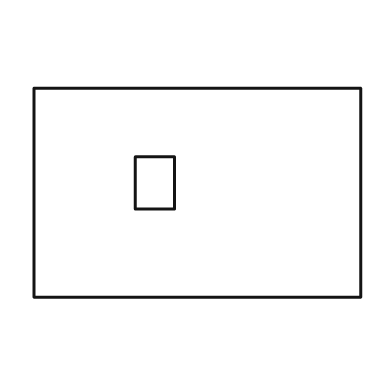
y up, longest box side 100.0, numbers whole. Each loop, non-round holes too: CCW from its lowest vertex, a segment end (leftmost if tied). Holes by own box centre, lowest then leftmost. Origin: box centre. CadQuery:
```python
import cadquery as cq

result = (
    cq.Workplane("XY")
    .moveTo(-50.0, -32.0)
    .lineTo(50.0, -32.0)
    .lineTo(50.0, 32.0)
    .lineTo(-50.0, 32.0)
    .close()
    .moveTo(-19.0, -5.0)
    .lineTo(-7.0, -5.0)
    .lineTo(-7.0, 11.0)
    .lineTo(-19.0, 11.0)
    .close()
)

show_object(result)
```